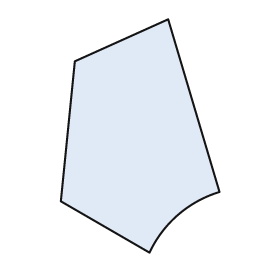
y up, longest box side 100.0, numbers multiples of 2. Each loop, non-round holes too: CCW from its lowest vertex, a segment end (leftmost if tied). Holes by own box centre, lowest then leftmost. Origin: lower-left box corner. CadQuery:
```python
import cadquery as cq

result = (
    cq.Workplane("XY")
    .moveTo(38.0, 0.0)
    .threePointArc((50.0, 16.0), (68.0, 26.0))
    .lineTo(46.0, 100.0)
    .lineTo(6.0, 82.0)
    .lineTo(0.0, 22.0)
    .close()
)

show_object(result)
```